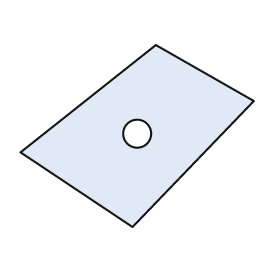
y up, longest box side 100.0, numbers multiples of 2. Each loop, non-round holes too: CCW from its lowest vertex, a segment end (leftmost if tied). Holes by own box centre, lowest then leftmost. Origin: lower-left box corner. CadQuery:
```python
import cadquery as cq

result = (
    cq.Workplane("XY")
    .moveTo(48.0, 0.0)
    .lineTo(100.0, 54.0)
    .lineTo(58.0, 78.0)
    .lineTo(0.0, 32.0)
    .close()
    .moveTo(50.0, 40.0)
    .circle(6.0)
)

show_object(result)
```